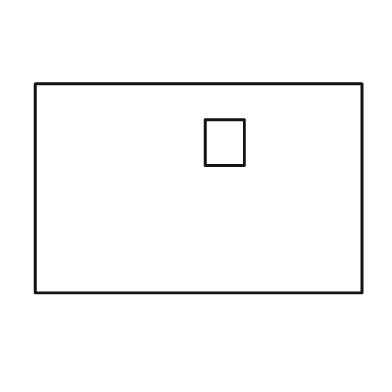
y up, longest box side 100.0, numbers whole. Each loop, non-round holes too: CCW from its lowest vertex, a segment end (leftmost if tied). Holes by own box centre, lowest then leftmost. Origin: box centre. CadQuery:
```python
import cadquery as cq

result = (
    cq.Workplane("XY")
    .moveTo(-50.0, -32.0)
    .lineTo(50.0, -32.0)
    .lineTo(50.0, 32.0)
    .lineTo(-50.0, 32.0)
    .close()
    .moveTo(2.0, 7.0)
    .lineTo(14.0, 7.0)
    .lineTo(14.0, 21.0)
    .lineTo(2.0, 21.0)
    .close()
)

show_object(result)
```